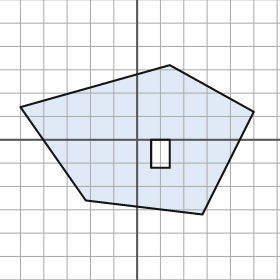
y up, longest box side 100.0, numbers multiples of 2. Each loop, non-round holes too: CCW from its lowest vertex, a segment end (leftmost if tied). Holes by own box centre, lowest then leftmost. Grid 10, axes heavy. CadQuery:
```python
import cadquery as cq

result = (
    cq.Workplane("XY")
    .moveTo(28.0, -32.0)
    .lineTo(50.0, 12.0)
    .lineTo(14.0, 32.0)
    .lineTo(-50.0, 14.0)
    .lineTo(-22.0, -26.0)
    .close()
    .moveTo(6.0, -12.0)
    .lineTo(14.0, -12.0)
    .lineTo(14.0, 0.0)
    .lineTo(6.0, 0.0)
    .close()
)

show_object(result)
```